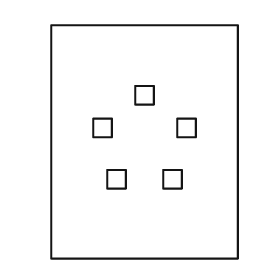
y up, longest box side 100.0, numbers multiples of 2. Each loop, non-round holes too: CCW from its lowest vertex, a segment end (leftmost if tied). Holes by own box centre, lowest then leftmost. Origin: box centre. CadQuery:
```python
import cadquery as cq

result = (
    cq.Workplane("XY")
    .moveTo(-40.0, -50.0)
    .lineTo(40.0, -50.0)
    .lineTo(40.0, 50.0)
    .lineTo(-40.0, 50.0)
    .close()
    .moveTo(-16.0, -20.0)
    .lineTo(-8.0, -20.0)
    .lineTo(-8.0, -12.0)
    .lineTo(-16.0, -12.0)
    .close()
    .moveTo(8.0, -20.0)
    .lineTo(16.0, -20.0)
    .lineTo(16.0, -12.0)
    .lineTo(8.0, -12.0)
    .close()
    .moveTo(-22.0, 2.0)
    .lineTo(-14.0, 2.0)
    .lineTo(-14.0, 10.0)
    .lineTo(-22.0, 10.0)
    .close()
    .moveTo(14.0, 2.0)
    .lineTo(22.0, 2.0)
    .lineTo(22.0, 10.0)
    .lineTo(14.0, 10.0)
    .close()
    .moveTo(-4.0, 16.0)
    .lineTo(4.0, 16.0)
    .lineTo(4.0, 24.0)
    .lineTo(-4.0, 24.0)
    .close()
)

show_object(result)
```